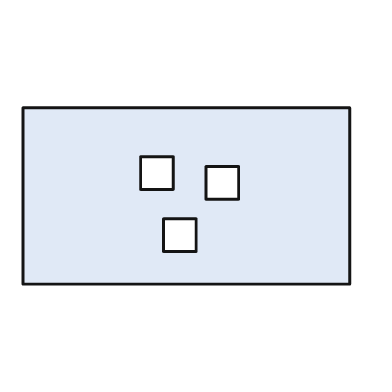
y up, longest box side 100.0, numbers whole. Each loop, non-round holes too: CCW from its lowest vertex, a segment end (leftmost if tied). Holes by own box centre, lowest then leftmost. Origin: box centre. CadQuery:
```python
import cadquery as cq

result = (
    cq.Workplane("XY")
    .moveTo(-50.0, -27.0)
    .lineTo(50.0, -27.0)
    .lineTo(50.0, 27.0)
    .lineTo(-50.0, 27.0)
    .close()
    .moveTo(-7.0, -17.0)
    .lineTo(3.0, -17.0)
    .lineTo(3.0, -7.0)
    .lineTo(-7.0, -7.0)
    .close()
    .moveTo(6.0, -1.0)
    .lineTo(16.0, -1.0)
    .lineTo(16.0, 9.0)
    .lineTo(6.0, 9.0)
    .close()
    .moveTo(-14.0, 2.0)
    .lineTo(-4.0, 2.0)
    .lineTo(-4.0, 12.0)
    .lineTo(-14.0, 12.0)
    .close()
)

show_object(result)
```